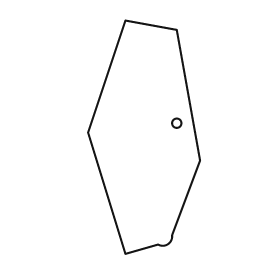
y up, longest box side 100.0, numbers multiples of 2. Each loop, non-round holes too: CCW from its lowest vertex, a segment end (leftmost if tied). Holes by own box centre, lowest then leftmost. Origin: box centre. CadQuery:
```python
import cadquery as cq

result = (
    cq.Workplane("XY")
    .moveTo(-8.0, -50.0)
    .lineTo(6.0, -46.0)
    .threePointArc((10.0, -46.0), (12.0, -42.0))
    .lineTo(24.0, -10.0)
    .lineTo(14.0, 46.0)
    .lineTo(-8.0, 50.0)
    .lineTo(-24.0, 2.0)
    .close()
    .moveTo(14.0, 6.0)
    .circle(2.0)
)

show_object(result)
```